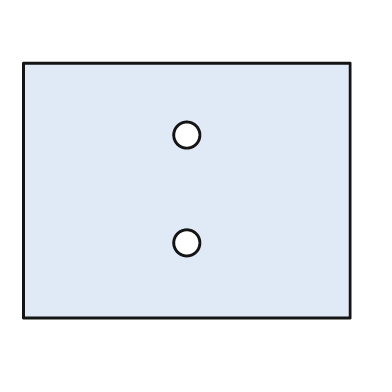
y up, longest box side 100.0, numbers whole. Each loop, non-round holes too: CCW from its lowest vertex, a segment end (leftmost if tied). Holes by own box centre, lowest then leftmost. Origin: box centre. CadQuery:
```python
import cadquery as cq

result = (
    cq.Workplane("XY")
    .moveTo(-50.0, -39.0)
    .lineTo(50.0, -39.0)
    .lineTo(50.0, 39.0)
    .lineTo(-50.0, 39.0)
    .close()
    .moveTo(0.0, -16.0)
    .circle(4.0)
    .moveTo(0.0, 17.0)
    .circle(4.0)
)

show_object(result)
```